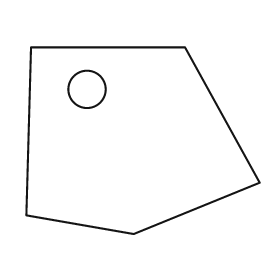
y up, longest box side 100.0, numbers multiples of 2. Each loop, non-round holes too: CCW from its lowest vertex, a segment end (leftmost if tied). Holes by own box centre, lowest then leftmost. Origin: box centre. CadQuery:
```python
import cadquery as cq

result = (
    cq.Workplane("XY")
    .moveTo(-4.0, -40.0)
    .lineTo(50.0, -18.0)
    .lineTo(18.0, 40.0)
    .lineTo(-48.0, 40.0)
    .lineTo(-50.0, -32.0)
    .close()
    .moveTo(-24.0, 22.0)
    .circle(8.0)
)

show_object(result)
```